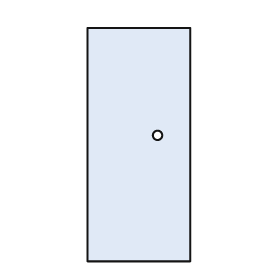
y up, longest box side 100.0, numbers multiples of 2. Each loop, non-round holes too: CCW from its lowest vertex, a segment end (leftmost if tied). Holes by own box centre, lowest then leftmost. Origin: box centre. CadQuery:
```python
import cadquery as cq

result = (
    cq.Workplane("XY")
    .moveTo(-22.0, -50.0)
    .lineTo(22.0, -50.0)
    .lineTo(22.0, 50.0)
    .lineTo(-22.0, 50.0)
    .close()
    .moveTo(8.0, 4.0)
    .circle(2.0)
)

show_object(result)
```